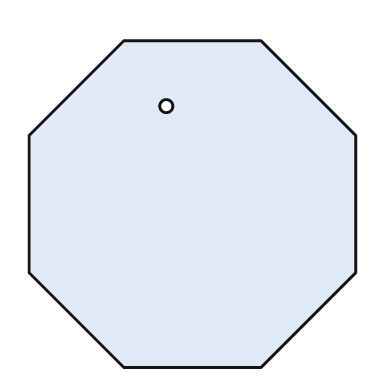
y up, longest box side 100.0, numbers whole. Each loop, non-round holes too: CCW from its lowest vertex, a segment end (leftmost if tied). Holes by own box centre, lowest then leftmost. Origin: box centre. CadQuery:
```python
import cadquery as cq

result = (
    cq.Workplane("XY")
    .moveTo(-21.0, -50.0)
    .lineTo(21.0, -50.0)
    .lineTo(50.0, -21.0)
    .lineTo(50.0, 21.0)
    .lineTo(21.0, 50.0)
    .lineTo(-21.0, 50.0)
    .lineTo(-50.0, 21.0)
    .lineTo(-50.0, -21.0)
    .close()
    .moveTo(-8.0, 30.0)
    .circle(2.0)
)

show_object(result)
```